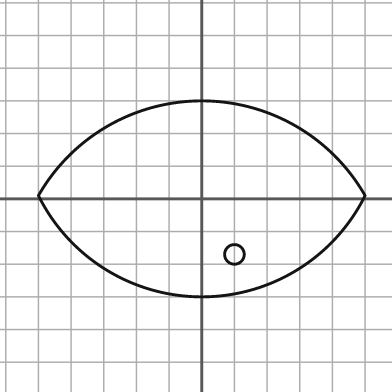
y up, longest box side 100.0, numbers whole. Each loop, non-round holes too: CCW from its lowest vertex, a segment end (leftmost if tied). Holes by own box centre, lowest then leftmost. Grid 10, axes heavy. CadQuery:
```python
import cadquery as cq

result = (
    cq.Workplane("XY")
    .moveTo(-50.0, 1.0)
    .threePointArc((0.0, -30.0), (50.0, 1.0))
    .threePointArc((0.0, 30.0), (-50.0, 1.0))
    .close()
    .moveTo(10.0, -17.0)
    .circle(3.0)
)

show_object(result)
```